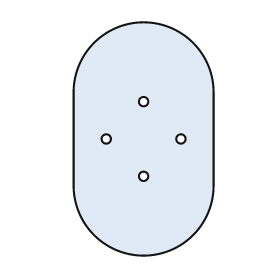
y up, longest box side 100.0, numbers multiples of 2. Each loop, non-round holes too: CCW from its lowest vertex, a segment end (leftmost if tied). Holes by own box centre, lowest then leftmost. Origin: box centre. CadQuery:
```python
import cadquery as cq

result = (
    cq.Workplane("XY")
    .moveTo(-30.0, -20.0)
    .threePointArc((0.0, -50.0), (30.0, -20.0))
    .lineTo(30.0, 20.0)
    .threePointArc((0.0, 50.0), (-30.0, 20.0))
    .close()
    .moveTo(0.0, -16.0)
    .circle(2.0)
    .moveTo(-16.0, 0.0)
    .circle(2.0)
    .moveTo(16.0, 0.0)
    .circle(2.0)
    .moveTo(0.0, 16.0)
    .circle(2.0)
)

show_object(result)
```